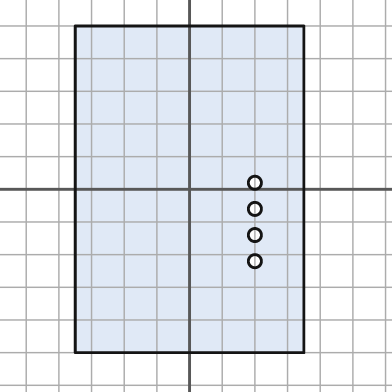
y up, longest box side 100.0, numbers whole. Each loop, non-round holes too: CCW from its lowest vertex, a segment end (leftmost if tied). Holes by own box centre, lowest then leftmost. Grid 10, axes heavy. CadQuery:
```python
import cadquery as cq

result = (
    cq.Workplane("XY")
    .moveTo(-35.0, -50.0)
    .lineTo(35.0, -50.0)
    .lineTo(35.0, 50.0)
    .lineTo(-35.0, 50.0)
    .close()
    .moveTo(20.0, -22.0)
    .circle(2.0)
    .moveTo(20.0, -14.0)
    .circle(2.0)
    .moveTo(20.0, -6.0)
    .circle(2.0)
    .moveTo(20.0, 2.0)
    .circle(2.0)
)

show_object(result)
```